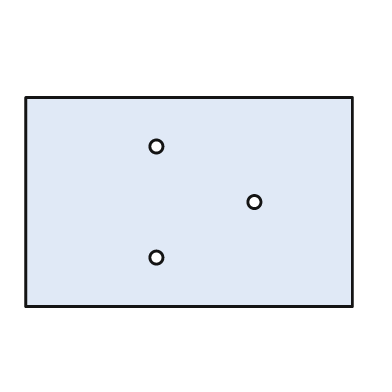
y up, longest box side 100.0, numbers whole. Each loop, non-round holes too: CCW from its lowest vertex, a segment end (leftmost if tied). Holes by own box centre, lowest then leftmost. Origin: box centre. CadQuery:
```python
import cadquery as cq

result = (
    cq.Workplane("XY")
    .moveTo(-50.0, -32.0)
    .lineTo(50.0, -32.0)
    .lineTo(50.0, 32.0)
    .lineTo(-50.0, 32.0)
    .close()
    .moveTo(-10.0, -17.0)
    .circle(2.0)
    .moveTo(20.0, 0.0)
    .circle(2.0)
    .moveTo(-10.0, 17.0)
    .circle(2.0)
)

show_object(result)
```